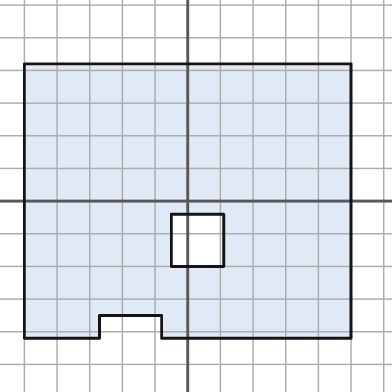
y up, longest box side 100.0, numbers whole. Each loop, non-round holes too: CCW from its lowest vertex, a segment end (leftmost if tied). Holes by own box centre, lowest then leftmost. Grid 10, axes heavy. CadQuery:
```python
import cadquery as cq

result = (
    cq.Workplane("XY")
    .moveTo(-50.0, -42.0)
    .lineTo(-27.0, -42.0)
    .lineTo(-27.0, -35.0)
    .lineTo(-8.0, -35.0)
    .lineTo(-8.0, -42.0)
    .lineTo(50.0, -42.0)
    .lineTo(50.0, 42.0)
    .lineTo(-50.0, 42.0)
    .close()
    .moveTo(-5.0, -20.0)
    .lineTo(11.0, -20.0)
    .lineTo(11.0, -4.0)
    .lineTo(-5.0, -4.0)
    .close()
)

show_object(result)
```